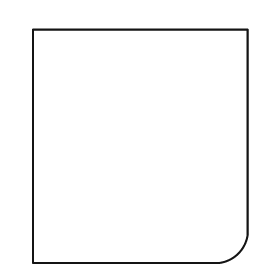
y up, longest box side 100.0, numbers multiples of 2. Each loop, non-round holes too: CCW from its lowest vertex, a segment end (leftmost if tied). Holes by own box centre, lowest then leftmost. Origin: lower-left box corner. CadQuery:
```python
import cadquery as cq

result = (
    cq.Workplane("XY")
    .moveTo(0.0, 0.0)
    .lineTo(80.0, 0.0)
    .threePointArc((88.0, 4.0), (92.0, 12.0))
    .lineTo(92.0, 100.0)
    .lineTo(0.0, 100.0)
    .close()
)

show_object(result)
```